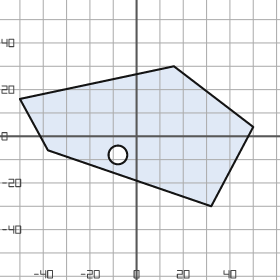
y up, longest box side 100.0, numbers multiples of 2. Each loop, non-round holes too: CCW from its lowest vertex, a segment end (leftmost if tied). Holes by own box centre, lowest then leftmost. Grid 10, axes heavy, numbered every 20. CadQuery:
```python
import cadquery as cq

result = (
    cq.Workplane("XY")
    .moveTo(32.0, -30.0)
    .lineTo(50.0, 4.0)
    .lineTo(16.0, 30.0)
    .lineTo(-50.0, 16.0)
    .lineTo(-38.0, -6.0)
    .close()
    .moveTo(-8.0, -8.0)
    .circle(4.0)
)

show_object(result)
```